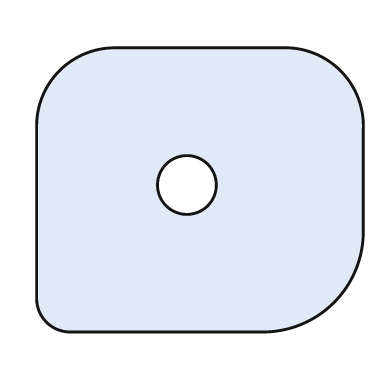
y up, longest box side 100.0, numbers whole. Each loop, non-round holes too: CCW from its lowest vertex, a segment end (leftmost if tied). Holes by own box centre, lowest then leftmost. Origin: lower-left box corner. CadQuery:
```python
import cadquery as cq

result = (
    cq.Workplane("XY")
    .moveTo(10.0, 0.0)
    .lineTo(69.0, 0.0)
    .threePointArc((91.0, 9.0), (100.0, 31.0))
    .lineTo(100.0, 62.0)
    .threePointArc((93.0, 80.0), (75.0, 87.0))
    .lineTo(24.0, 87.0)
    .threePointArc((7.0, 80.0), (0.0, 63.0))
    .lineTo(0.0, 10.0)
    .threePointArc((3.0, 3.0), (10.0, 0.0))
    .close()
    .moveTo(46.0, 45.0)
    .circle(9.0)
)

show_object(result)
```